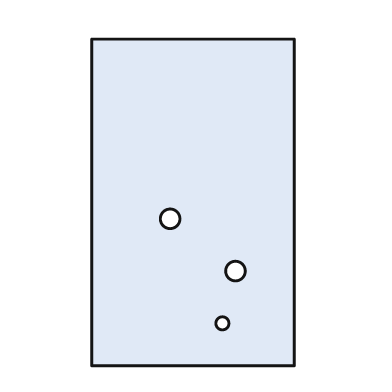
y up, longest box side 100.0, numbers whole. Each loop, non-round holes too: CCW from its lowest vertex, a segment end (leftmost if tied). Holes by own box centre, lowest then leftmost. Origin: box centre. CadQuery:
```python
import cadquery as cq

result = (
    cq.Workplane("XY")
    .moveTo(-31.0, -50.0)
    .lineTo(31.0, -50.0)
    .lineTo(31.0, 50.0)
    .lineTo(-31.0, 50.0)
    .close()
    .moveTo(9.0, -37.0)
    .circle(2.0)
    .moveTo(13.0, -21.0)
    .circle(3.0)
    .moveTo(-7.0, -5.0)
    .circle(3.0)
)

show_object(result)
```